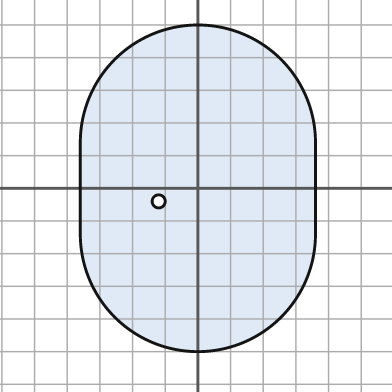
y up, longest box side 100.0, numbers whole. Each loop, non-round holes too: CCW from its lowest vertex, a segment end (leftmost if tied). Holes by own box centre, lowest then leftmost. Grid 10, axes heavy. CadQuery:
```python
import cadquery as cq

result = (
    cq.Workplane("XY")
    .moveTo(-36.0, -14.0)
    .threePointArc((0.0, -50.0), (36.0, -14.0))
    .lineTo(36.0, 14.0)
    .threePointArc((0.0, 50.0), (-36.0, 14.0))
    .close()
    .moveTo(-12.0, -4.0)
    .circle(2.0)
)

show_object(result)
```